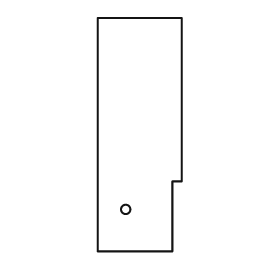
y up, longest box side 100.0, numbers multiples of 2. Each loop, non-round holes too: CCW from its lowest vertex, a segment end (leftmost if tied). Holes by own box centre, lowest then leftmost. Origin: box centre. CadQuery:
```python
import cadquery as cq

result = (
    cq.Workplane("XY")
    .moveTo(-18.0, -50.0)
    .lineTo(14.0, -50.0)
    .lineTo(14.0, -20.0)
    .lineTo(18.0, -20.0)
    .lineTo(18.0, 50.0)
    .lineTo(-18.0, 50.0)
    .close()
    .moveTo(-6.0, -32.0)
    .circle(2.0)
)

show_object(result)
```